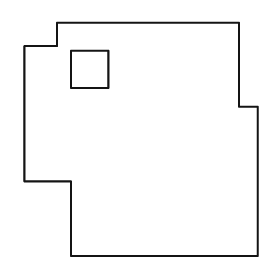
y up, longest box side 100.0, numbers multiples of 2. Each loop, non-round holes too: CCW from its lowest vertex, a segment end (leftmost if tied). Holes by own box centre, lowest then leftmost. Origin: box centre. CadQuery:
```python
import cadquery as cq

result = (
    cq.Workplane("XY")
    .moveTo(-30.0, -50.0)
    .lineTo(50.0, -50.0)
    .lineTo(50.0, 14.0)
    .lineTo(42.0, 14.0)
    .lineTo(42.0, 50.0)
    .lineTo(-36.0, 50.0)
    .lineTo(-36.0, 40.0)
    .lineTo(-50.0, 40.0)
    .lineTo(-50.0, -18.0)
    .lineTo(-30.0, -18.0)
    .close()
    .moveTo(-30.0, 22.0)
    .lineTo(-14.0, 22.0)
    .lineTo(-14.0, 38.0)
    .lineTo(-30.0, 38.0)
    .close()
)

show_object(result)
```